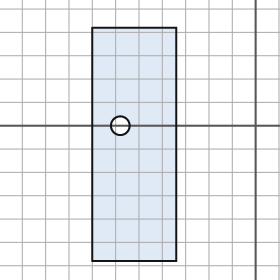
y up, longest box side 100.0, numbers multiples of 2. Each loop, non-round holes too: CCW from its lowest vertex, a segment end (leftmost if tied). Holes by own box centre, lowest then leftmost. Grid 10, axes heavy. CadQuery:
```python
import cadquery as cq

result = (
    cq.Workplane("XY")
    .moveTo(-70.0, -58.0)
    .lineTo(-34.0, -58.0)
    .lineTo(-34.0, 42.0)
    .lineTo(-70.0, 42.0)
    .close()
    .moveTo(-58.0, 0.0)
    .circle(4.0)
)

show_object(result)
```